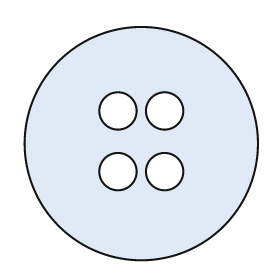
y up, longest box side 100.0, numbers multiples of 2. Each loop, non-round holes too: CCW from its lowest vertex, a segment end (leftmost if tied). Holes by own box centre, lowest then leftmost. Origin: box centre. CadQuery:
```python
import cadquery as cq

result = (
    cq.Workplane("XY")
    .moveTo(0.0, 0.0)
    .circle(50.0)
    .moveTo(-10.0, -12.0)
    .circle(8.0)
    .moveTo(10.0, -12.0)
    .circle(8.0)
    .moveTo(-10.0, 14.0)
    .circle(8.0)
    .moveTo(10.0, 14.0)
    .circle(8.0)
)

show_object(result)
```